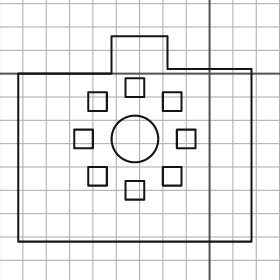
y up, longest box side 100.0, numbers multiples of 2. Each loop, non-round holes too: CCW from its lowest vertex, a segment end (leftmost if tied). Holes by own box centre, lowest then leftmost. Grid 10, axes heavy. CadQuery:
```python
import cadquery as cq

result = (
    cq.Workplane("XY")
    .moveTo(-82.0, -72.0)
    .lineTo(18.0, -72.0)
    .lineTo(18.0, 2.0)
    .lineTo(-18.0, 2.0)
    .lineTo(-18.0, 16.0)
    .lineTo(-42.0, 16.0)
    .lineTo(-42.0, 0.0)
    .lineTo(-82.0, 0.0)
    .close()
    .moveTo(-36.0, -54.0)
    .lineTo(-28.0, -54.0)
    .lineTo(-28.0, -46.0)
    .lineTo(-36.0, -46.0)
    .close()
    .moveTo(-52.0, -48.0)
    .lineTo(-44.0, -48.0)
    .lineTo(-44.0, -40.0)
    .lineTo(-52.0, -40.0)
    .close()
    .moveTo(-20.0, -48.0)
    .lineTo(-12.0, -48.0)
    .lineTo(-12.0, -40.0)
    .lineTo(-20.0, -40.0)
    .close()
    .moveTo(-58.0, -32.0)
    .lineTo(-50.0, -32.0)
    .lineTo(-50.0, -24.0)
    .lineTo(-58.0, -24.0)
    .close()
    .moveTo(-32.0, -28.0)
    .circle(10.0)
    .moveTo(-14.0, -32.0)
    .lineTo(-6.0, -32.0)
    .lineTo(-6.0, -24.0)
    .lineTo(-14.0, -24.0)
    .close()
    .moveTo(-52.0, -16.0)
    .lineTo(-44.0, -16.0)
    .lineTo(-44.0, -8.0)
    .lineTo(-52.0, -8.0)
    .close()
    .moveTo(-20.0, -16.0)
    .lineTo(-12.0, -16.0)
    .lineTo(-12.0, -8.0)
    .lineTo(-20.0, -8.0)
    .close()
    .moveTo(-36.0, -10.0)
    .lineTo(-28.0, -10.0)
    .lineTo(-28.0, -2.0)
    .lineTo(-36.0, -2.0)
    .close()
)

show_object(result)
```